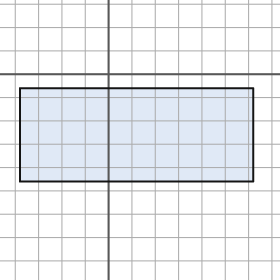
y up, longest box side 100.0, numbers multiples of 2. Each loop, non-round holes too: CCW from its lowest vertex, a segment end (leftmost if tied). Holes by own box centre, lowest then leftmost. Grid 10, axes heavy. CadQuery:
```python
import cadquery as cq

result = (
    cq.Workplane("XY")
    .moveTo(-38.0, -46.0)
    .lineTo(62.0, -46.0)
    .lineTo(62.0, -6.0)
    .lineTo(-38.0, -6.0)
    .close()
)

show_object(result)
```